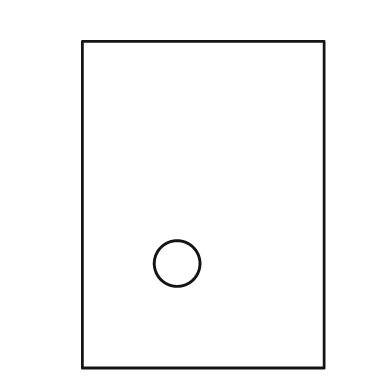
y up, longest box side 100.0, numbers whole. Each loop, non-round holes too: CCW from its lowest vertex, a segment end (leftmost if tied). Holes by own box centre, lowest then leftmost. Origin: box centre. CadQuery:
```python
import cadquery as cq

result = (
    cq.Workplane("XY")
    .moveTo(-37.0, -50.0)
    .lineTo(37.0, -50.0)
    .lineTo(37.0, 50.0)
    .lineTo(-37.0, 50.0)
    .close()
    .moveTo(-8.0, -18.0)
    .circle(7.0)
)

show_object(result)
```